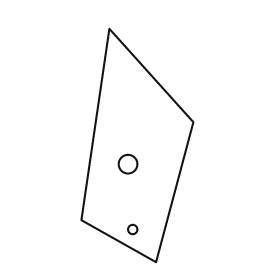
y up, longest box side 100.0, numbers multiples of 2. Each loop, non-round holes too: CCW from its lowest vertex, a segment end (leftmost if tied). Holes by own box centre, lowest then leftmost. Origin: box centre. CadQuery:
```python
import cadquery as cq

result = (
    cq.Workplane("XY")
    .moveTo(8.0, -50.0)
    .lineTo(24.0, 10.0)
    .lineTo(-12.0, 50.0)
    .lineTo(-24.0, -32.0)
    .close()
    .moveTo(-2.0, -36.0)
    .circle(2.0)
    .moveTo(-4.0, -8.0)
    .circle(4.0)
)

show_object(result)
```